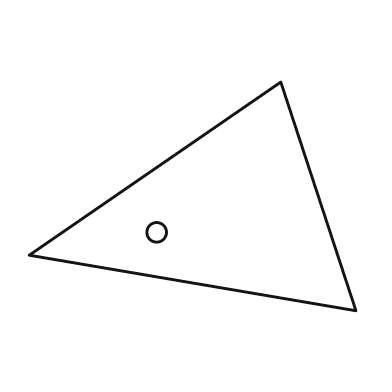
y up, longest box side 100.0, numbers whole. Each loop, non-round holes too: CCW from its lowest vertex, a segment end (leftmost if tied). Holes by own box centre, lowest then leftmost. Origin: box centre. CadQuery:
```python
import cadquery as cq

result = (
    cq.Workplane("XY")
    .moveTo(50.0, -35.0)
    .lineTo(27.0, 35.0)
    .lineTo(-50.0, -18.0)
    .close()
    .moveTo(-11.0, -11.0)
    .circle(3.0)
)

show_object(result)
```